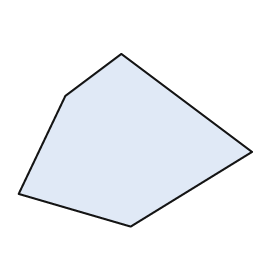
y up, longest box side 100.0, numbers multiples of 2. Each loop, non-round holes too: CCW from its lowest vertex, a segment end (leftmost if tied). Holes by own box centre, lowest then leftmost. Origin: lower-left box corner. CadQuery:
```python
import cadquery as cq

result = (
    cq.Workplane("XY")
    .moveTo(48.0, 0.0)
    .lineTo(100.0, 32.0)
    .lineTo(44.0, 74.0)
    .lineTo(20.0, 56.0)
    .lineTo(0.0, 14.0)
    .close()
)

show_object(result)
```